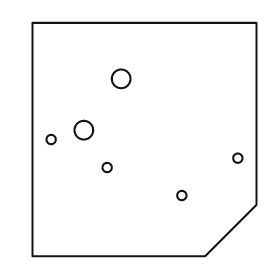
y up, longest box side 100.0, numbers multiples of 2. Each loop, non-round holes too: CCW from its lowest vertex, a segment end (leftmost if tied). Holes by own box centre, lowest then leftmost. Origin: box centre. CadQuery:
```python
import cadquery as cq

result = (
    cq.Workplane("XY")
    .moveTo(-48.0, -50.0)
    .lineTo(26.0, -50.0)
    .lineTo(48.0, -28.0)
    .lineTo(48.0, 50.0)
    .lineTo(-48.0, 50.0)
    .close()
    .moveTo(16.0, -24.0)
    .circle(2.0)
    .moveTo(-16.0, -12.0)
    .circle(2.0)
    .moveTo(40.0, -8.0)
    .circle(2.0)
    .moveTo(-40.0, 0.0)
    .circle(2.0)
    .moveTo(-26.0, 4.0)
    .circle(4.0)
    .moveTo(-10.0, 26.0)
    .circle(4.0)
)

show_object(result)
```